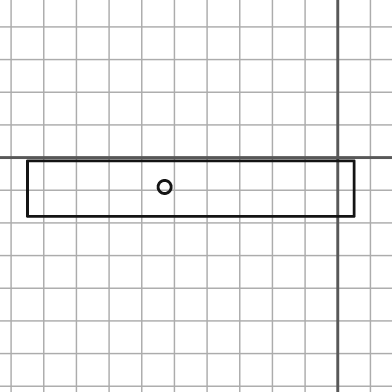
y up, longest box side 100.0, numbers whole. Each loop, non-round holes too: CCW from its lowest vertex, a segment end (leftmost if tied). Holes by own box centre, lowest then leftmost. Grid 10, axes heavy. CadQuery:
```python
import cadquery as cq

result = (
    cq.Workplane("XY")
    .moveTo(-95.0, -18.0)
    .lineTo(5.0, -18.0)
    .lineTo(5.0, -1.0)
    .lineTo(-95.0, -1.0)
    .close()
    .moveTo(-53.0, -9.0)
    .circle(2.0)
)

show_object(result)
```